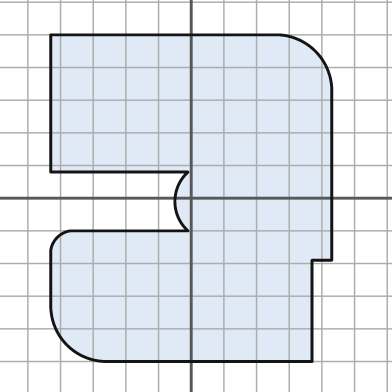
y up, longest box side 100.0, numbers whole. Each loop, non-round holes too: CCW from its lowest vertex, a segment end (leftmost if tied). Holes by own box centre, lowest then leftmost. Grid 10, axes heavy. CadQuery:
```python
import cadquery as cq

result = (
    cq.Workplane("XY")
    .moveTo(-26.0, -50.0)
    .lineTo(37.0, -50.0)
    .lineTo(37.0, -19.0)
    .lineTo(43.0, -19.0)
    .lineTo(43.0, 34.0)
    .threePointArc((38.0, 45.0), (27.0, 50.0))
    .lineTo(-43.0, 50.0)
    .lineTo(-43.0, 8.0)
    .lineTo(-1.0, 8.0)
    .threePointArc((-5.0, -1.0), (-1.0, -10.0))
    .lineTo(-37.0, -10.0)
    .threePointArc((-41.0, -12.0), (-43.0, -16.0))
    .lineTo(-43.0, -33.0)
    .threePointArc((-38.0, -45.0), (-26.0, -50.0))
    .close()
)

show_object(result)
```